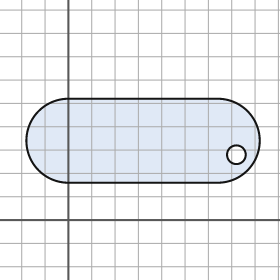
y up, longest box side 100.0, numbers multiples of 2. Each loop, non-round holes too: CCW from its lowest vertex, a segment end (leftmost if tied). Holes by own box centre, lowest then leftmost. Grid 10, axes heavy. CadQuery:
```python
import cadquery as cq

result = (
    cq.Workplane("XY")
    .moveTo(0.0, 16.0)
    .lineTo(64.0, 16.0)
    .threePointArc((82.0, 34.0), (64.0, 52.0))
    .lineTo(0.0, 52.0)
    .threePointArc((-18.0, 34.0), (0.0, 16.0))
    .close()
    .moveTo(72.0, 28.0)
    .circle(4.0)
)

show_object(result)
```